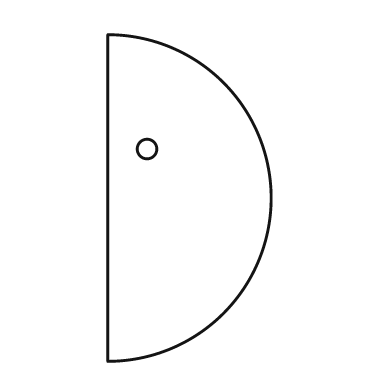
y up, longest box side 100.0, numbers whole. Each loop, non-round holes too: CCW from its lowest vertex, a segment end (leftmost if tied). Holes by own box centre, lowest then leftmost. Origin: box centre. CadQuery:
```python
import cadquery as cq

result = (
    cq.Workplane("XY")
    .moveTo(-25.0, -50.0)
    .threePointArc((25.0, 0.0), (-25.0, 50.0))
    .close()
    .moveTo(-13.0, 15.0)
    .circle(3.0)
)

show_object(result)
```